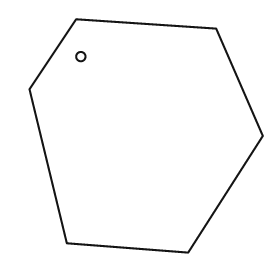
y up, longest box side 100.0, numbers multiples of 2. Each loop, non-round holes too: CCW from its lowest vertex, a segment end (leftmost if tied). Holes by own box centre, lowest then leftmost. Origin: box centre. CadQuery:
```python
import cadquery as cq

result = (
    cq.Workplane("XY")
    .moveTo(18.0, -50.0)
    .lineTo(50.0, 0.0)
    .lineTo(30.0, 46.0)
    .lineTo(-30.0, 50.0)
    .lineTo(-50.0, 20.0)
    .lineTo(-34.0, -46.0)
    .close()
    .moveTo(-28.0, 34.0)
    .circle(2.0)
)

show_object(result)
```